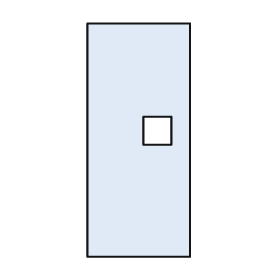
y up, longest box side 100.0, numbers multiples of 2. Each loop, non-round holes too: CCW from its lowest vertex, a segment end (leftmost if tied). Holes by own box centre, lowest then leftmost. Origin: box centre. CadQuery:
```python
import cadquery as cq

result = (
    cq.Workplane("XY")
    .moveTo(-22.0, -50.0)
    .lineTo(22.0, -50.0)
    .lineTo(22.0, 50.0)
    .lineTo(-22.0, 50.0)
    .close()
    .moveTo(2.0, -2.0)
    .lineTo(14.0, -2.0)
    .lineTo(14.0, 10.0)
    .lineTo(2.0, 10.0)
    .close()
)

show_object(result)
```